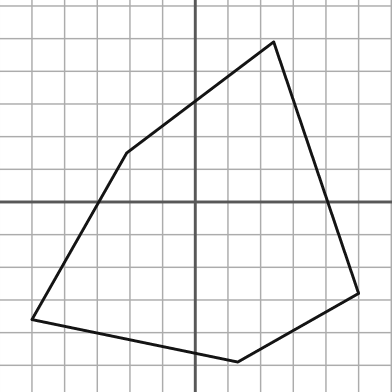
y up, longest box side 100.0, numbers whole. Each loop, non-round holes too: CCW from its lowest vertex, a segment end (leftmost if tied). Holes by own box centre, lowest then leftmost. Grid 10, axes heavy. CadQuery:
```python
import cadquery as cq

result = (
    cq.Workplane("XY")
    .moveTo(13.0, -49.0)
    .lineTo(50.0, -28.0)
    .lineTo(24.0, 49.0)
    .lineTo(-21.0, 15.0)
    .lineTo(-50.0, -36.0)
    .close()
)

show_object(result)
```